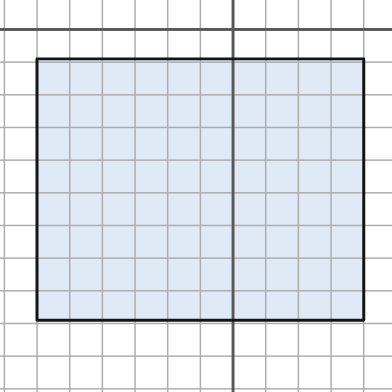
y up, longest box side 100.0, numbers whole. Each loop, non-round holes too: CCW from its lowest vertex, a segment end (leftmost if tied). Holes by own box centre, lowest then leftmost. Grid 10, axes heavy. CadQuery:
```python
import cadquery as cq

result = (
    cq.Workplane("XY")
    .moveTo(-60.0, -89.0)
    .lineTo(40.0, -89.0)
    .lineTo(40.0, -9.0)
    .lineTo(-60.0, -9.0)
    .close()
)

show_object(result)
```